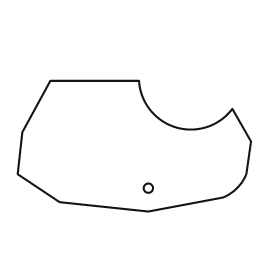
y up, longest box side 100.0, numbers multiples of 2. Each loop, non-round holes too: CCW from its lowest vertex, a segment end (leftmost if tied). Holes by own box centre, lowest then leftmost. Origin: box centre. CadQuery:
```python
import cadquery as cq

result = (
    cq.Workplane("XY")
    .moveTo(6.0, -28.0)
    .lineTo(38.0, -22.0)
    .threePointArc((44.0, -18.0), (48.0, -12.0))
    .lineTo(50.0, 2.0)
    .lineTo(42.0, 16.0)
    .threePointArc((18.0, 8.0), (2.0, 28.0))
    .lineTo(-36.0, 28.0)
    .lineTo(-48.0, 6.0)
    .lineTo(-50.0, -12.0)
    .lineTo(-32.0, -24.0)
    .close()
    .moveTo(6.0, -18.0)
    .circle(2.0)
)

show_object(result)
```